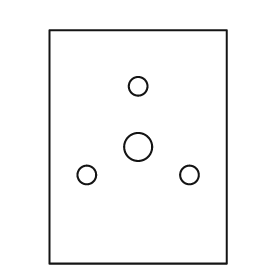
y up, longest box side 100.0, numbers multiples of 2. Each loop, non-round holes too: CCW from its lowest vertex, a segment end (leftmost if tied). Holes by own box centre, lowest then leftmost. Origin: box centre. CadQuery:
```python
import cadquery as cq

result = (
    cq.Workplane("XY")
    .moveTo(-38.0, -50.0)
    .lineTo(38.0, -50.0)
    .lineTo(38.0, 50.0)
    .lineTo(-38.0, 50.0)
    .close()
    .moveTo(-22.0, -12.0)
    .circle(4.0)
    .moveTo(22.0, -12.0)
    .circle(4.0)
    .moveTo(0.0, 0.0)
    .circle(6.0)
    .moveTo(0.0, 26.0)
    .circle(4.0)
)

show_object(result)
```